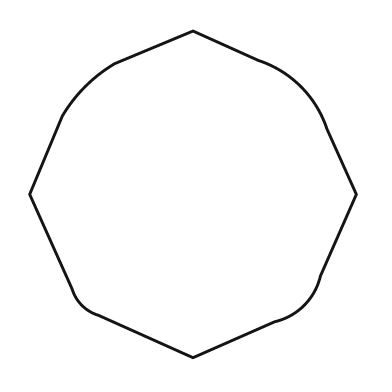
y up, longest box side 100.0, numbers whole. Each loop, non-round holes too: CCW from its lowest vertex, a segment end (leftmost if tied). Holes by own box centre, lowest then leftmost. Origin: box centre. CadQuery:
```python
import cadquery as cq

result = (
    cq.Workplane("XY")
    .moveTo(0.0, -50.0)
    .lineTo(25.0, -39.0)
    .threePointArc((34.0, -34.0), (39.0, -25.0))
    .lineTo(50.0, 0.0)
    .lineTo(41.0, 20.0)
    .threePointArc((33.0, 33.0), (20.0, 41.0))
    .lineTo(0.0, 50.0)
    .lineTo(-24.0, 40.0)
    .threePointArc((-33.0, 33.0), (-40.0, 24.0))
    .lineTo(-50.0, 0.0)
    .lineTo(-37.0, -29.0)
    .threePointArc((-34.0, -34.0), (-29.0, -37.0))
    .close()
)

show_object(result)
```